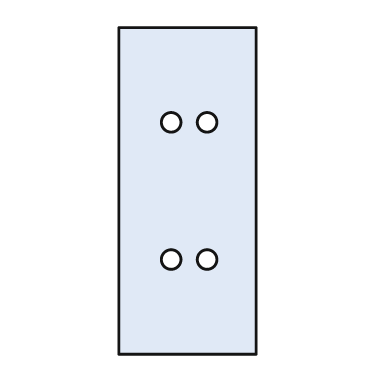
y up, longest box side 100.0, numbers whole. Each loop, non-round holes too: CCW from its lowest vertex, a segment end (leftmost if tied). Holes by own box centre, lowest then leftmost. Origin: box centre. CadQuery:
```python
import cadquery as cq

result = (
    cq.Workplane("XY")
    .moveTo(-21.0, -50.0)
    .lineTo(21.0, -50.0)
    .lineTo(21.0, 50.0)
    .lineTo(-21.0, 50.0)
    .close()
    .moveTo(-5.0, -21.0)
    .circle(3.0)
    .moveTo(6.0, -21.0)
    .circle(3.0)
    .moveTo(-5.0, 21.0)
    .circle(3.0)
    .moveTo(6.0, 21.0)
    .circle(3.0)
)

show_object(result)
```